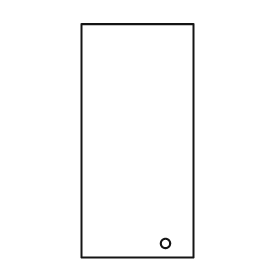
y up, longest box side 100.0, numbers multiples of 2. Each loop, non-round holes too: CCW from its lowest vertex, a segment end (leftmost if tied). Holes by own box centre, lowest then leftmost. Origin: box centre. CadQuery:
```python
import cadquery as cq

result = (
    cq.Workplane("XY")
    .moveTo(-24.0, -50.0)
    .lineTo(24.0, -50.0)
    .lineTo(24.0, 50.0)
    .lineTo(-24.0, 50.0)
    .close()
    .moveTo(12.0, -44.0)
    .circle(2.0)
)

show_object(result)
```